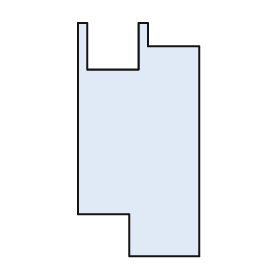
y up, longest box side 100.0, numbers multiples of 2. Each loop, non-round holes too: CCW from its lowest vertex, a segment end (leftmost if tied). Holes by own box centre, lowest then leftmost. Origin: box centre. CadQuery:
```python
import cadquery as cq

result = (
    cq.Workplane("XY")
    .moveTo(-4.0, -50.0)
    .lineTo(26.0, -50.0)
    .lineTo(26.0, 40.0)
    .lineTo(4.0, 40.0)
    .lineTo(4.0, 50.0)
    .lineTo(0.0, 50.0)
    .lineTo(0.0, 30.0)
    .lineTo(-22.0, 30.0)
    .lineTo(-22.0, 50.0)
    .lineTo(-26.0, 50.0)
    .lineTo(-26.0, -32.0)
    .lineTo(-4.0, -32.0)
    .close()
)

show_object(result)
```